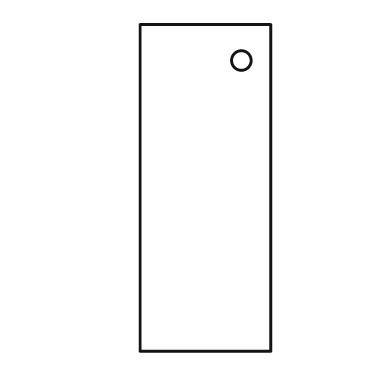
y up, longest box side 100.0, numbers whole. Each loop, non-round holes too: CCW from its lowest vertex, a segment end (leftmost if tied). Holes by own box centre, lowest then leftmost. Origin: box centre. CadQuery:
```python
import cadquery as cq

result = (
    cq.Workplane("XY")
    .moveTo(-20.0, -50.0)
    .lineTo(20.0, -50.0)
    .lineTo(20.0, 50.0)
    .lineTo(-20.0, 50.0)
    .close()
    .moveTo(11.0, 39.0)
    .circle(3.0)
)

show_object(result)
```